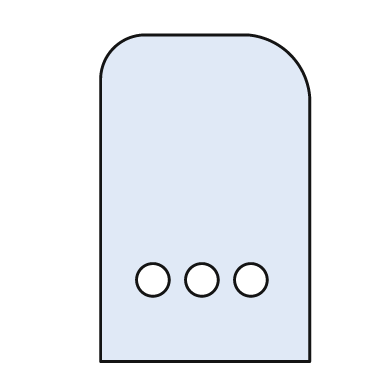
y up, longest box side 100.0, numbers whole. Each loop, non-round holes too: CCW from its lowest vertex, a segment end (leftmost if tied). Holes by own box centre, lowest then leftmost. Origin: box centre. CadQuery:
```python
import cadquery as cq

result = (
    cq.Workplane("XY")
    .moveTo(-32.0, -50.0)
    .lineTo(32.0, -50.0)
    .lineTo(32.0, 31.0)
    .threePointArc((26.0, 44.0), (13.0, 50.0))
    .lineTo(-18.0, 50.0)
    .threePointArc((-28.0, 46.0), (-32.0, 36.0))
    .close()
    .moveTo(-16.0, -25.0)
    .circle(5.0)
    .moveTo(-1.0, -25.0)
    .circle(5.0)
    .moveTo(14.0, -25.0)
    .circle(5.0)
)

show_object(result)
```